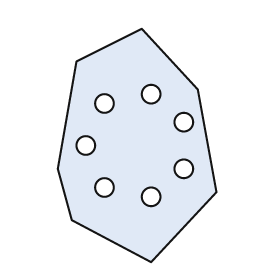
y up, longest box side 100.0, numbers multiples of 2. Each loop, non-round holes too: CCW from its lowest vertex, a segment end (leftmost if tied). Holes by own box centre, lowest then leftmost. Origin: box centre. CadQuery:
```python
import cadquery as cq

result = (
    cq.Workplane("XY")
    .moveTo(6.0, -50.0)
    .lineTo(34.0, -20.0)
    .lineTo(26.0, 24.0)
    .lineTo(2.0, 50.0)
    .lineTo(-26.0, 36.0)
    .lineTo(-34.0, -10.0)
    .lineTo(-28.0, -32.0)
    .close()
    .moveTo(6.0, -22.0)
    .circle(4.0)
    .moveTo(-14.0, -18.0)
    .circle(4.0)
    .moveTo(20.0, -10.0)
    .circle(4.0)
    .moveTo(-22.0, 0.0)
    .circle(4.0)
    .moveTo(20.0, 10.0)
    .circle(4.0)
    .moveTo(-14.0, 18.0)
    .circle(4.0)
    .moveTo(6.0, 22.0)
    .circle(4.0)
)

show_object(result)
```